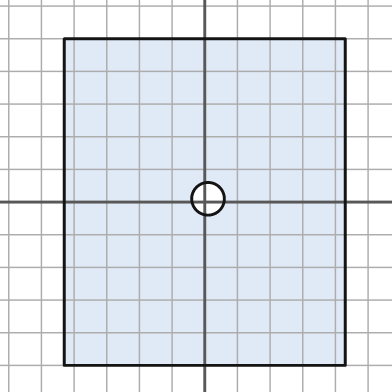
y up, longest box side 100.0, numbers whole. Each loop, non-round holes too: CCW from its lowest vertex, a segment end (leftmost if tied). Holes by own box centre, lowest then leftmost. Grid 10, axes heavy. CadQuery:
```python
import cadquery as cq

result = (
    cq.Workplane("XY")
    .moveTo(-43.0, -50.0)
    .lineTo(43.0, -50.0)
    .lineTo(43.0, 50.0)
    .lineTo(-43.0, 50.0)
    .close()
    .moveTo(1.0, 1.0)
    .circle(5.0)
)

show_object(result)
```